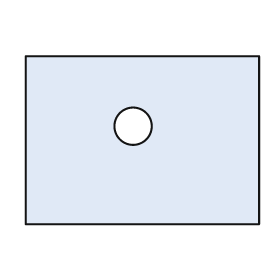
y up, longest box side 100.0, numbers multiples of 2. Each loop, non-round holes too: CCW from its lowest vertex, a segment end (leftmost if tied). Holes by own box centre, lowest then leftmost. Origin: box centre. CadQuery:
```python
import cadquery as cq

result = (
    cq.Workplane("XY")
    .moveTo(-50.0, -36.0)
    .lineTo(50.0, -36.0)
    .lineTo(50.0, 36.0)
    .lineTo(-50.0, 36.0)
    .close()
    .moveTo(-4.0, 6.0)
    .circle(8.0)
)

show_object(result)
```